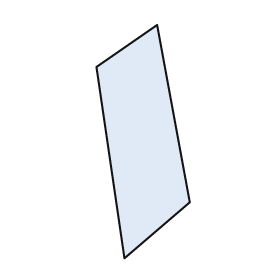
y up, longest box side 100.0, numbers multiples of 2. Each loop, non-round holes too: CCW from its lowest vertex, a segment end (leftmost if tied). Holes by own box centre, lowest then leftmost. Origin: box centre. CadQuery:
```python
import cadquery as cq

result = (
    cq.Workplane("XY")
    .moveTo(-8.0, -50.0)
    .lineTo(20.0, -26.0)
    .lineTo(6.0, 50.0)
    .lineTo(-20.0, 32.0)
    .close()
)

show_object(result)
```